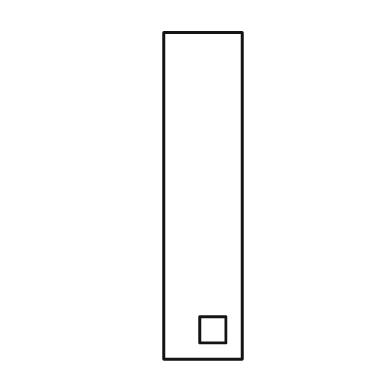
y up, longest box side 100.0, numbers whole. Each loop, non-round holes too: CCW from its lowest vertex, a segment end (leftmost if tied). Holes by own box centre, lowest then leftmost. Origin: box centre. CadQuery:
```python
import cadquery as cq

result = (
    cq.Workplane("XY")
    .moveTo(-12.0, -50.0)
    .lineTo(12.0, -50.0)
    .lineTo(12.0, 50.0)
    .lineTo(-12.0, 50.0)
    .close()
    .moveTo(-1.0, -45.0)
    .lineTo(7.0, -45.0)
    .lineTo(7.0, -37.0)
    .lineTo(-1.0, -37.0)
    .close()
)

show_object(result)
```